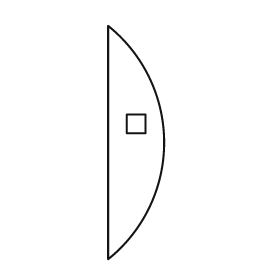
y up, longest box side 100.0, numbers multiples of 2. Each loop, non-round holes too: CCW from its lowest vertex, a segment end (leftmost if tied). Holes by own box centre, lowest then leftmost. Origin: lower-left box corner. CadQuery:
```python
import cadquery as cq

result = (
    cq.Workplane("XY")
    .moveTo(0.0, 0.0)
    .threePointArc((24.0, 50.0), (0.0, 100.0))
    .close()
    .moveTo(8.0, 54.0)
    .lineTo(16.0, 54.0)
    .lineTo(16.0, 62.0)
    .lineTo(8.0, 62.0)
    .close()
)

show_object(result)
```